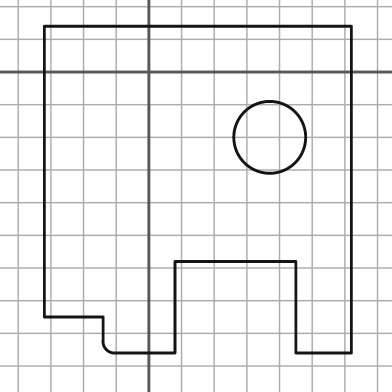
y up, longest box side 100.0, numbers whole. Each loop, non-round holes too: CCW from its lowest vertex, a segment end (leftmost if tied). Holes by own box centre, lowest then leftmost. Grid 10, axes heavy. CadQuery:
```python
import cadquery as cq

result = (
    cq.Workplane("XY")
    .moveTo(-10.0, -86.0)
    .lineTo(8.0, -86.0)
    .lineTo(8.0, -58.0)
    .lineTo(45.0, -58.0)
    .lineTo(45.0, -86.0)
    .lineTo(62.0, -86.0)
    .lineTo(62.0, 14.0)
    .lineTo(-32.0, 14.0)
    .lineTo(-32.0, -75.0)
    .lineTo(-14.0, -75.0)
    .lineTo(-14.0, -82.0)
    .threePointArc((-13.0, -85.0), (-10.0, -86.0))
    .close()
    .moveTo(37.0, -20.0)
    .circle(11.0)
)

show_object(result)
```